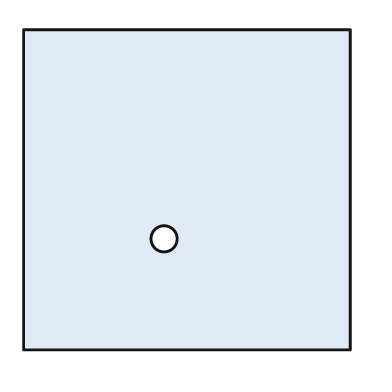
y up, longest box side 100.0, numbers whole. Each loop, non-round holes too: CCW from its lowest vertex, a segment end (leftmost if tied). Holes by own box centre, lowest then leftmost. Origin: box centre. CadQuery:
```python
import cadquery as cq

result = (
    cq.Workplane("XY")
    .moveTo(-50.0, -49.0)
    .lineTo(50.0, -49.0)
    .lineTo(50.0, 49.0)
    .lineTo(-50.0, 49.0)
    .close()
    .moveTo(-7.0, -15.0)
    .circle(4.0)
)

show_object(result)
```